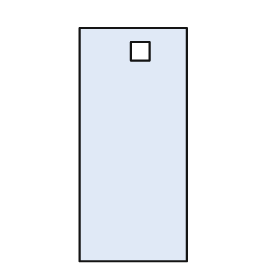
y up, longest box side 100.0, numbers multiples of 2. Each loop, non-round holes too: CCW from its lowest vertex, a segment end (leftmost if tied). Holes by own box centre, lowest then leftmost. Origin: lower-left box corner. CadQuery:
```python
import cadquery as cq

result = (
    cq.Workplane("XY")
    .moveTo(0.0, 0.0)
    .lineTo(46.0, 0.0)
    .lineTo(46.0, 100.0)
    .lineTo(0.0, 100.0)
    .close()
    .moveTo(22.0, 86.0)
    .lineTo(30.0, 86.0)
    .lineTo(30.0, 94.0)
    .lineTo(22.0, 94.0)
    .close()
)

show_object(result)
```